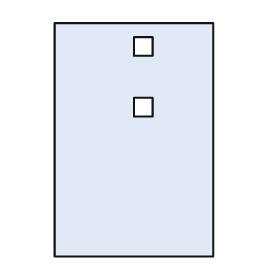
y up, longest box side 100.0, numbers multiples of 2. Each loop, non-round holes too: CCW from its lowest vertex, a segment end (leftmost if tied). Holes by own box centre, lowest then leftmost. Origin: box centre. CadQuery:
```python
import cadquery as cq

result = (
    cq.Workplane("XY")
    .moveTo(-34.0, -50.0)
    .lineTo(34.0, -50.0)
    .lineTo(34.0, 50.0)
    .lineTo(-34.0, 50.0)
    .close()
    .moveTo(0.0, 10.0)
    .lineTo(8.0, 10.0)
    .lineTo(8.0, 18.0)
    .lineTo(0.0, 18.0)
    .close()
    .moveTo(0.0, 36.0)
    .lineTo(8.0, 36.0)
    .lineTo(8.0, 44.0)
    .lineTo(0.0, 44.0)
    .close()
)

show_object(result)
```